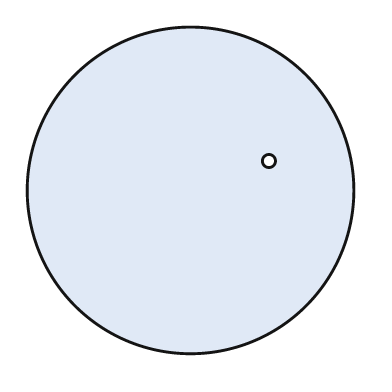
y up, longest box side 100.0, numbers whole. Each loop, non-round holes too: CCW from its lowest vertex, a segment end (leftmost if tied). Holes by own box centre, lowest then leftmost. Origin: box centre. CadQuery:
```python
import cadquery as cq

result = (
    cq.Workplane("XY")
    .moveTo(0.0, 0.0)
    .circle(50.0)
    .moveTo(24.0, 9.0)
    .circle(2.0)
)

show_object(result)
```